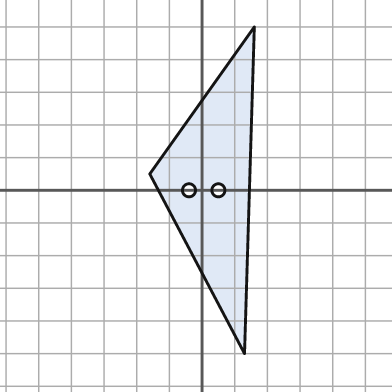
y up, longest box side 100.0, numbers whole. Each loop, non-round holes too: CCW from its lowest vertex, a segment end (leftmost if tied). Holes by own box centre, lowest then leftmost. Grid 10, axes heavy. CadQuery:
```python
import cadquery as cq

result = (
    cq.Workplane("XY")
    .moveTo(13.0, -50.0)
    .lineTo(16.0, 50.0)
    .lineTo(-16.0, 5.0)
    .close()
    .moveTo(-4.0, 0.0)
    .circle(2.0)
    .moveTo(5.0, 0.0)
    .circle(2.0)
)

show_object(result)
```